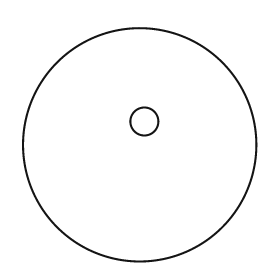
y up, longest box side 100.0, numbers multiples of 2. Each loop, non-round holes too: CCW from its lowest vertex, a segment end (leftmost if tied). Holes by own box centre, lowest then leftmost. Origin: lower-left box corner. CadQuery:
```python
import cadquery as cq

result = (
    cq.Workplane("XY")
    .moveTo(50.0, 50.0)
    .circle(50.0)
    .moveTo(52.0, 60.0)
    .circle(6.0)
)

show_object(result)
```